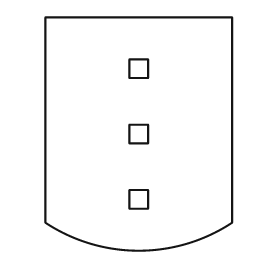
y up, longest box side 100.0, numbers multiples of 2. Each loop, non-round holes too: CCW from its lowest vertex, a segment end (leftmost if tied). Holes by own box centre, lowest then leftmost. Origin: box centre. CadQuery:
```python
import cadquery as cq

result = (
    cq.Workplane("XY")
    .moveTo(-40.0, -38.0)
    .threePointArc((0.0, -50.0), (40.0, -38.0))
    .lineTo(40.0, 50.0)
    .lineTo(-40.0, 50.0)
    .close()
    .moveTo(-4.0, -32.0)
    .lineTo(4.0, -32.0)
    .lineTo(4.0, -24.0)
    .lineTo(-4.0, -24.0)
    .close()
    .moveTo(-4.0, -4.0)
    .lineTo(4.0, -4.0)
    .lineTo(4.0, 4.0)
    .lineTo(-4.0, 4.0)
    .close()
    .moveTo(-4.0, 24.0)
    .lineTo(4.0, 24.0)
    .lineTo(4.0, 32.0)
    .lineTo(-4.0, 32.0)
    .close()
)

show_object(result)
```